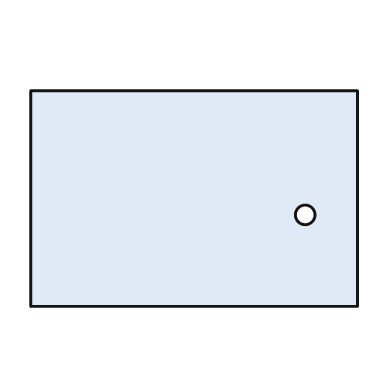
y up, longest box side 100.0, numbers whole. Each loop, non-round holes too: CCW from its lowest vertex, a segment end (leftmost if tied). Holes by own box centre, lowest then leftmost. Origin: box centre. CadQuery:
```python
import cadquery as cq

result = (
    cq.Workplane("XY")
    .moveTo(-50.0, -33.0)
    .lineTo(50.0, -33.0)
    .lineTo(50.0, 33.0)
    .lineTo(-50.0, 33.0)
    .close()
    .moveTo(34.0, -5.0)
    .circle(3.0)
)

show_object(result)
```